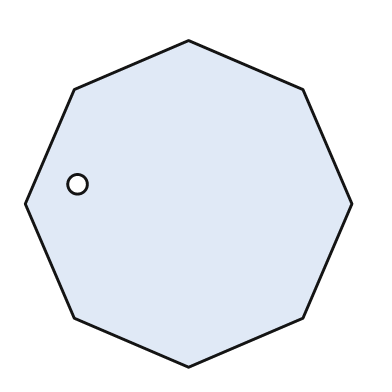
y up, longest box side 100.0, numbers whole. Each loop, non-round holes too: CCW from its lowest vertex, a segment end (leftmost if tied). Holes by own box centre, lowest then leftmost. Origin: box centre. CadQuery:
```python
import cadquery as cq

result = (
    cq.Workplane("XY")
    .moveTo(0.0, -50.0)
    .lineTo(35.0, -35.0)
    .lineTo(50.0, 0.0)
    .lineTo(35.0, 35.0)
    .lineTo(0.0, 50.0)
    .lineTo(-35.0, 35.0)
    .lineTo(-50.0, 0.0)
    .lineTo(-35.0, -35.0)
    .close()
    .moveTo(-34.0, 6.0)
    .circle(3.0)
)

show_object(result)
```